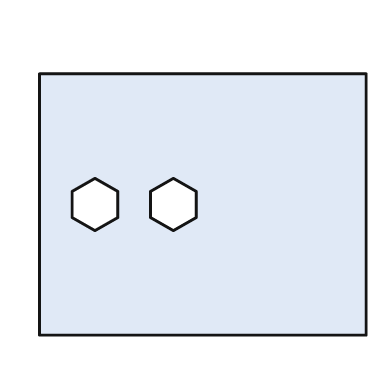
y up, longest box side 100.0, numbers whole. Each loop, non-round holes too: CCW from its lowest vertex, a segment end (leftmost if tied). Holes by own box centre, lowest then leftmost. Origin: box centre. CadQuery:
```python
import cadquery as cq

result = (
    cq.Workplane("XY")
    .moveTo(-50.0, -40.0)
    .lineTo(50.0, -40.0)
    .lineTo(50.0, 40.0)
    .lineTo(-50.0, 40.0)
    .close()
    .moveTo(-33.0, -8.0)
    .lineTo(-26.0, -4.0)
    .lineTo(-26.0, 4.0)
    .lineTo(-33.0, 8.0)
    .lineTo(-40.0, 4.0)
    .lineTo(-40.0, -4.0)
    .close()
    .moveTo(-9.0, -8.0)
    .lineTo(-2.0, -4.0)
    .lineTo(-2.0, 4.0)
    .lineTo(-9.0, 8.0)
    .lineTo(-16.0, 4.0)
    .lineTo(-16.0, -4.0)
    .close()
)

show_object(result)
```